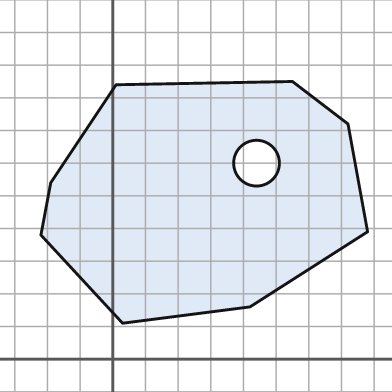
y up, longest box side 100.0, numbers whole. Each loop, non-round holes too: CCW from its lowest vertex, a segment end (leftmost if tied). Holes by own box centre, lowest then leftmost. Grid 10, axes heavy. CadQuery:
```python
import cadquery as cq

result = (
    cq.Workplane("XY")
    .moveTo(3.0, 11.0)
    .lineTo(42.0, 16.0)
    .lineTo(78.0, 39.0)
    .lineTo(72.0, 72.0)
    .lineTo(55.0, 85.0)
    .lineTo(1.0, 84.0)
    .lineTo(-19.0, 54.0)
    .lineTo(-22.0, 38.0)
    .close()
    .moveTo(44.0, 60.0)
    .circle(7.0)
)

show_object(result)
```